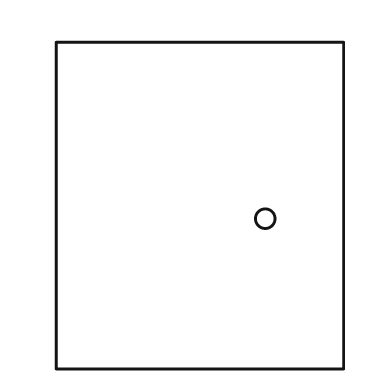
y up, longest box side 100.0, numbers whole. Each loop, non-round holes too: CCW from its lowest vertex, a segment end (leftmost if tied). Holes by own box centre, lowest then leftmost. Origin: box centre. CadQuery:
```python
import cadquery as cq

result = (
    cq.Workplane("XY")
    .moveTo(-44.0, -50.0)
    .lineTo(44.0, -50.0)
    .lineTo(44.0, 50.0)
    .lineTo(-44.0, 50.0)
    .close()
    .moveTo(20.0, -4.0)
    .circle(3.0)
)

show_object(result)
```